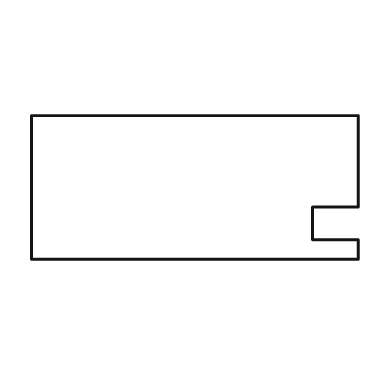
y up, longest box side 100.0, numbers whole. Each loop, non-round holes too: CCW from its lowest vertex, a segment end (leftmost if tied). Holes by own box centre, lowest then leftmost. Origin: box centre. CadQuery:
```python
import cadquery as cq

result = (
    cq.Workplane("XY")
    .moveTo(-50.0, -22.0)
    .lineTo(50.0, -22.0)
    .lineTo(50.0, -16.0)
    .lineTo(36.0, -16.0)
    .lineTo(36.0, -6.0)
    .lineTo(50.0, -6.0)
    .lineTo(50.0, 22.0)
    .lineTo(-50.0, 22.0)
    .close()
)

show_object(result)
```